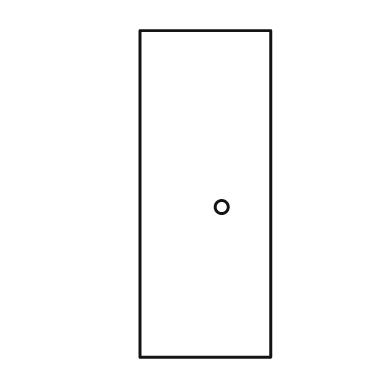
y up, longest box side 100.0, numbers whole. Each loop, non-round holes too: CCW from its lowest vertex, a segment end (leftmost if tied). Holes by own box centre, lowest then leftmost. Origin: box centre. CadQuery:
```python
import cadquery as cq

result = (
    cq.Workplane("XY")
    .moveTo(-20.0, -50.0)
    .lineTo(20.0, -50.0)
    .lineTo(20.0, 50.0)
    .lineTo(-20.0, 50.0)
    .close()
    .moveTo(5.0, -4.0)
    .circle(2.0)
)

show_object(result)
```